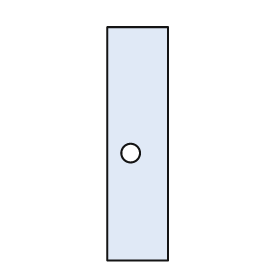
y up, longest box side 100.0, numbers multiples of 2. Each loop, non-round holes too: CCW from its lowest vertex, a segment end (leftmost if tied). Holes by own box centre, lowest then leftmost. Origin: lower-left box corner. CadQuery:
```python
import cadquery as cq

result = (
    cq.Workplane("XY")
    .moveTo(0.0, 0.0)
    .lineTo(26.0, 0.0)
    .lineTo(26.0, 100.0)
    .lineTo(0.0, 100.0)
    .close()
    .moveTo(10.0, 46.0)
    .circle(4.0)
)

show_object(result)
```